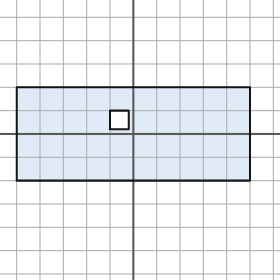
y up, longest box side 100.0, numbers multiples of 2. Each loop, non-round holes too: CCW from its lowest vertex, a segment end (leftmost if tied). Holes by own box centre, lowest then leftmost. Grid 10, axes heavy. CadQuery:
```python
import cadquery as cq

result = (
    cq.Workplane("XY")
    .moveTo(-50.0, -20.0)
    .lineTo(50.0, -20.0)
    .lineTo(50.0, 20.0)
    .lineTo(-50.0, 20.0)
    .close()
    .moveTo(-10.0, 2.0)
    .lineTo(-2.0, 2.0)
    .lineTo(-2.0, 10.0)
    .lineTo(-10.0, 10.0)
    .close()
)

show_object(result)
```